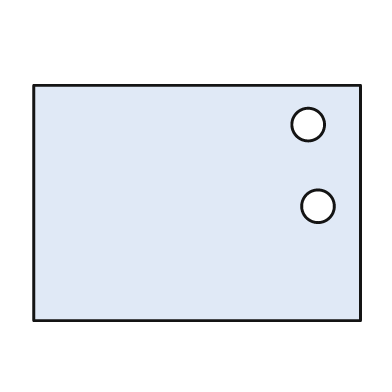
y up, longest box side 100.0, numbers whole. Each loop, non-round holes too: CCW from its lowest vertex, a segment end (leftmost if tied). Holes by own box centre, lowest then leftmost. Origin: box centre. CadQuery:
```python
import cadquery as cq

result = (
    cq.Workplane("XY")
    .moveTo(-50.0, -36.0)
    .lineTo(50.0, -36.0)
    .lineTo(50.0, 36.0)
    .lineTo(-50.0, 36.0)
    .close()
    .moveTo(37.0, -1.0)
    .circle(5.0)
    .moveTo(34.0, 24.0)
    .circle(5.0)
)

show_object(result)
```